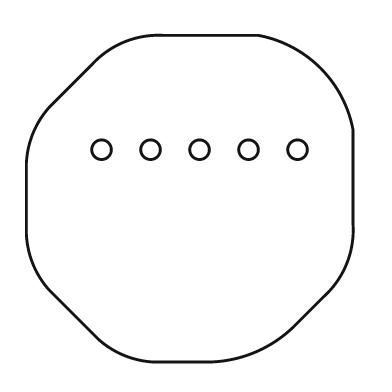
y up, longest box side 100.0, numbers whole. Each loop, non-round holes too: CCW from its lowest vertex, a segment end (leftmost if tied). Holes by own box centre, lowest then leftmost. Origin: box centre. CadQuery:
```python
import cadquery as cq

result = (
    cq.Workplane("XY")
    .moveTo(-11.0, -50.0)
    .lineTo(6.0, -50.0)
    .threePointArc((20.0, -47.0), (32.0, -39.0))
    .lineTo(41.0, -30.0)
    .threePointArc((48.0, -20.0), (50.0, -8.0))
    .lineTo(50.0, 21.0)
    .threePointArc((40.0, 40.0), (21.0, 50.0))
    .lineTo(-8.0, 50.0)
    .threePointArc((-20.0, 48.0), (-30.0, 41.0))
    .lineTo(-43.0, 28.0)
    .threePointArc((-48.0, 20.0), (-50.0, 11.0))
    .lineTo(-50.0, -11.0)
    .threePointArc((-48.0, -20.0), (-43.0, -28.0))
    .lineTo(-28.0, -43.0)
    .threePointArc((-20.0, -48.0), (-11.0, -50.0))
    .close()
    .moveTo(-27.0, 15.0)
    .circle(3.0)
    .moveTo(-12.0, 15.0)
    .circle(3.0)
    .moveTo(3.0, 15.0)
    .circle(3.0)
    .moveTo(18.0, 15.0)
    .circle(3.0)
    .moveTo(33.0, 15.0)
    .circle(3.0)
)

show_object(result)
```